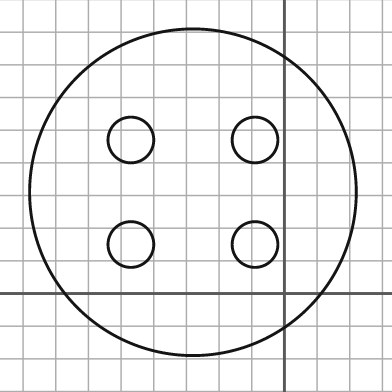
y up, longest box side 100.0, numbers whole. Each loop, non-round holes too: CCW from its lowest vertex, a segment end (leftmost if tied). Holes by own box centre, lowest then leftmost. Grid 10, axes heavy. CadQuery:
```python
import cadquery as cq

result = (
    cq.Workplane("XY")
    .moveTo(-28.0, 31.0)
    .circle(50.0)
    .moveTo(-47.0, 15.0)
    .circle(7.0)
    .moveTo(-9.0, 15.0)
    .circle(7.0)
    .moveTo(-47.0, 47.0)
    .circle(7.0)
    .moveTo(-9.0, 47.0)
    .circle(7.0)
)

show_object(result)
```